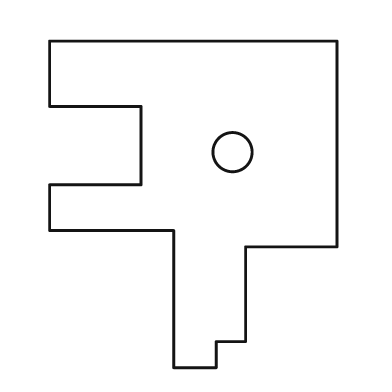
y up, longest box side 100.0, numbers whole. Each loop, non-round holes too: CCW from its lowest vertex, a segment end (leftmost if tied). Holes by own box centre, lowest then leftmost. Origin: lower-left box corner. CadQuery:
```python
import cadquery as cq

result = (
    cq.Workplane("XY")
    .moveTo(38.0, 0.0)
    .lineTo(51.0, 0.0)
    .lineTo(51.0, 8.0)
    .lineTo(60.0, 8.0)
    .lineTo(60.0, 37.0)
    .lineTo(88.0, 37.0)
    .lineTo(88.0, 100.0)
    .lineTo(0.0, 100.0)
    .lineTo(0.0, 80.0)
    .lineTo(28.0, 80.0)
    .lineTo(28.0, 56.0)
    .lineTo(0.0, 56.0)
    .lineTo(0.0, 42.0)
    .lineTo(38.0, 42.0)
    .close()
    .moveTo(56.0, 66.0)
    .circle(6.0)
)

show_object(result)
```